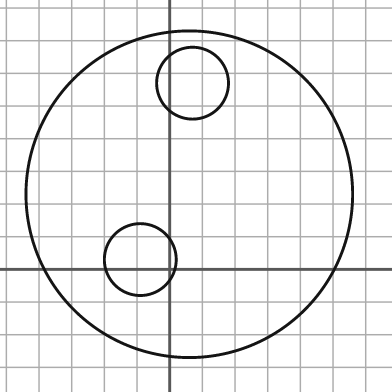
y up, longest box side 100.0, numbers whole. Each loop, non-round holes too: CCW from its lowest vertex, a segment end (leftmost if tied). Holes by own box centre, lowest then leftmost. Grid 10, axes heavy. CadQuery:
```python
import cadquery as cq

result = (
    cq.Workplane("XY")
    .moveTo(6.0, 23.0)
    .circle(50.0)
    .moveTo(-9.0, 3.0)
    .circle(11.0)
    .moveTo(7.0, 57.0)
    .circle(11.0)
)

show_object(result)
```